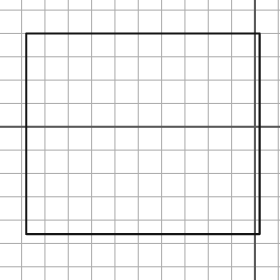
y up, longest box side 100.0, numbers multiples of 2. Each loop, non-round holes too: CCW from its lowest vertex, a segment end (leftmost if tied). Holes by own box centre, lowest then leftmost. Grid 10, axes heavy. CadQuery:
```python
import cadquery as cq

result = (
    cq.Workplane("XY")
    .moveTo(-98.0, -46.0)
    .lineTo(2.0, -46.0)
    .lineTo(2.0, 40.0)
    .lineTo(-98.0, 40.0)
    .close()
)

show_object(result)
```